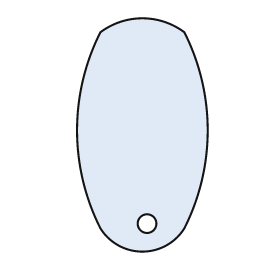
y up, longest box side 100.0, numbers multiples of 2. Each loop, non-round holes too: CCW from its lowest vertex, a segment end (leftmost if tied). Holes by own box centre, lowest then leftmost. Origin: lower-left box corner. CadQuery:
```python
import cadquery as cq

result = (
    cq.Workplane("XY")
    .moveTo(10.0, 10.0)
    .threePointArc((28.0, 0.0), (46.0, 10.0))
    .threePointArc((56.0, 52.0), (46.0, 94.0))
    .threePointArc((28.0, 100.0), (10.0, 94.0))
    .threePointArc((0.0, 52.0), (10.0, 10.0))
    .close()
    .moveTo(30.0, 12.0)
    .circle(4.0)
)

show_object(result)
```